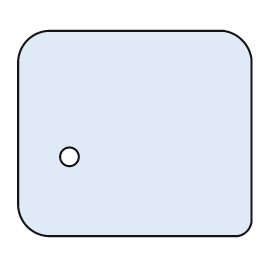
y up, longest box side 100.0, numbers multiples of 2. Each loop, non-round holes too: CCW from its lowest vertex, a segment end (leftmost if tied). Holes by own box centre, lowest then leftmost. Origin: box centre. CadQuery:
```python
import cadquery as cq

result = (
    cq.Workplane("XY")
    .moveTo(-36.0, -44.0)
    .lineTo(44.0, -44.0)
    .threePointArc((48.0, -42.0), (50.0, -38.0))
    .lineTo(50.0, 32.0)
    .threePointArc((46.0, 40.0), (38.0, 44.0))
    .lineTo(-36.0, 44.0)
    .threePointArc((-46.0, 40.0), (-50.0, 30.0))
    .lineTo(-50.0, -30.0)
    .threePointArc((-46.0, -40.0), (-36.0, -44.0))
    .close()
    .moveTo(-28.0, -10.0)
    .circle(4.0)
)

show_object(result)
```